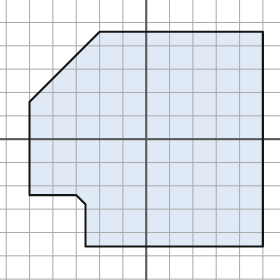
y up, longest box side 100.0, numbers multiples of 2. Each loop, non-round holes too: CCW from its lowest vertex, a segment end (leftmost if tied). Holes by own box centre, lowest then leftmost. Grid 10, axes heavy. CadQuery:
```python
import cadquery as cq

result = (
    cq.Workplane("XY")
    .moveTo(-26.0, -46.0)
    .lineTo(50.0, -46.0)
    .lineTo(50.0, 46.0)
    .lineTo(-20.0, 46.0)
    .lineTo(-50.0, 16.0)
    .lineTo(-50.0, -24.0)
    .lineTo(-30.0, -24.0)
    .lineTo(-26.0, -28.0)
    .close()
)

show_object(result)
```